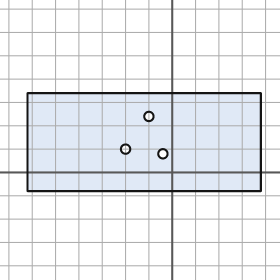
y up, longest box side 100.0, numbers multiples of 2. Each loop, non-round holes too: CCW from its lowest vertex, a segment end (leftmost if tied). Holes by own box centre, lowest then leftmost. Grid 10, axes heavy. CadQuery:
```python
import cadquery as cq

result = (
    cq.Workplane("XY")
    .moveTo(-62.0, -8.0)
    .lineTo(38.0, -8.0)
    .lineTo(38.0, 34.0)
    .lineTo(-62.0, 34.0)
    .close()
    .moveTo(-4.0, 8.0)
    .circle(2.0)
    .moveTo(-20.0, 10.0)
    .circle(2.0)
    .moveTo(-10.0, 24.0)
    .circle(2.0)
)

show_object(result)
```